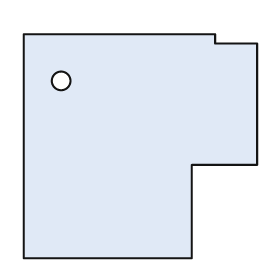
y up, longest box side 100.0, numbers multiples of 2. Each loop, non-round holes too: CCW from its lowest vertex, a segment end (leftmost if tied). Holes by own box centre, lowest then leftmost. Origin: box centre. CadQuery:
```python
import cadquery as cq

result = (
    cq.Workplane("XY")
    .moveTo(-50.0, -48.0)
    .lineTo(22.0, -48.0)
    .lineTo(22.0, -8.0)
    .lineTo(50.0, -8.0)
    .lineTo(50.0, 44.0)
    .lineTo(32.0, 44.0)
    .lineTo(32.0, 48.0)
    .lineTo(-50.0, 48.0)
    .close()
    .moveTo(-34.0, 28.0)
    .circle(4.0)
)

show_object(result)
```